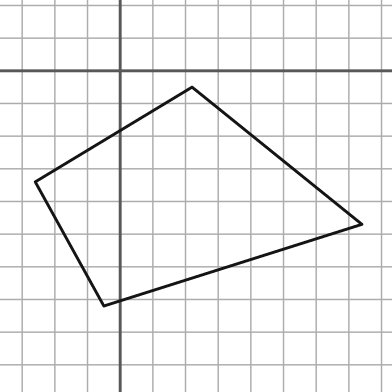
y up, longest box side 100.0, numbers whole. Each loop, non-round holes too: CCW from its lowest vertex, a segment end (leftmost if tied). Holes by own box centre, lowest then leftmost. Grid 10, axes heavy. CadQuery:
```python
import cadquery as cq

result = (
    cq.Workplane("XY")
    .moveTo(-5.0, -72.0)
    .lineTo(74.0, -47.0)
    .lineTo(22.0, -5.0)
    .lineTo(-26.0, -34.0)
    .close()
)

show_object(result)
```